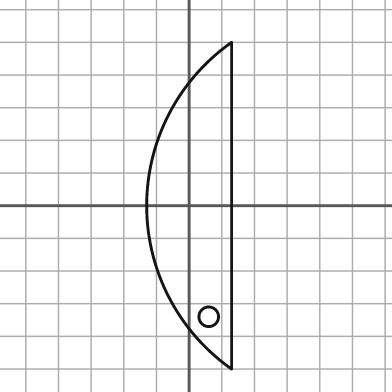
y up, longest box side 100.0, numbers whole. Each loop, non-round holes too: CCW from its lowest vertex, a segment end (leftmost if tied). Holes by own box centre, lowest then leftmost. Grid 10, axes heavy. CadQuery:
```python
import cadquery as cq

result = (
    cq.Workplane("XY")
    .moveTo(13.0, -50.0)
    .lineTo(13.0, 50.0)
    .threePointArc((-13.0, 0.0), (13.0, -50.0))
    .close()
    .moveTo(6.0, -34.0)
    .circle(3.0)
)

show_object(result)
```